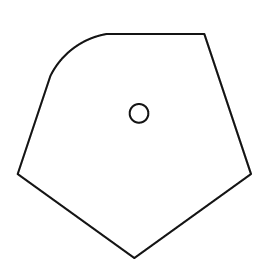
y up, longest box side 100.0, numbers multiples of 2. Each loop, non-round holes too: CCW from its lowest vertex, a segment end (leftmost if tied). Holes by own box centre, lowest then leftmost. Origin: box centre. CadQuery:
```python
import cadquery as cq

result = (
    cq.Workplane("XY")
    .moveTo(0.0, -48.0)
    .lineTo(50.0, -12.0)
    .lineTo(30.0, 48.0)
    .lineTo(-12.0, 48.0)
    .threePointArc((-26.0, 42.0), (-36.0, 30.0))
    .lineTo(-50.0, -12.0)
    .close()
    .moveTo(2.0, 14.0)
    .circle(4.0)
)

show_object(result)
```